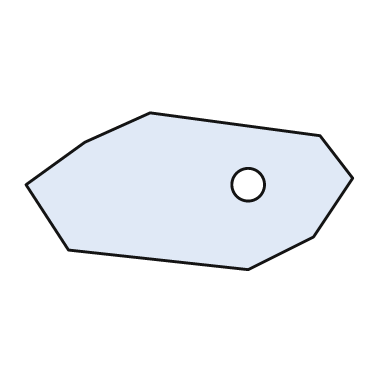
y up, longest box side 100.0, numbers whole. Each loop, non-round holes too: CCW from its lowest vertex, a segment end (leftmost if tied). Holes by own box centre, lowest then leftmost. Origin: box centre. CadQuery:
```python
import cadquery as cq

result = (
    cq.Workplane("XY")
    .moveTo(18.0, -24.0)
    .lineTo(38.0, -14.0)
    .lineTo(50.0, 4.0)
    .lineTo(40.0, 17.0)
    .lineTo(-12.0, 24.0)
    .lineTo(-32.0, 15.0)
    .lineTo(-50.0, 2.0)
    .lineTo(-37.0, -18.0)
    .close()
    .moveTo(18.0, 2.0)
    .circle(5.0)
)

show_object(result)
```